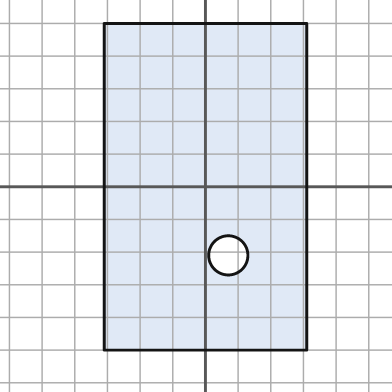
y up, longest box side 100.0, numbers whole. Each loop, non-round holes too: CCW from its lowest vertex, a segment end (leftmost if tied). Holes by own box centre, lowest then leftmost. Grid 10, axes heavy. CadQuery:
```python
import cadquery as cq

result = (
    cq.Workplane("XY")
    .moveTo(-31.0, -50.0)
    .lineTo(31.0, -50.0)
    .lineTo(31.0, 50.0)
    .lineTo(-31.0, 50.0)
    .close()
    .moveTo(7.0, -21.0)
    .circle(6.0)
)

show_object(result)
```